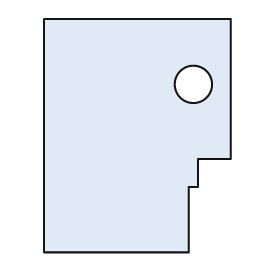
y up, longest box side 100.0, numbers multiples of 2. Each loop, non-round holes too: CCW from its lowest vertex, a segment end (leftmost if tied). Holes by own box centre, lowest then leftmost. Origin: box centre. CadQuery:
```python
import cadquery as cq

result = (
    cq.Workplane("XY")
    .moveTo(-40.0, -50.0)
    .lineTo(22.0, -50.0)
    .lineTo(22.0, -22.0)
    .lineTo(26.0, -22.0)
    .lineTo(26.0, -10.0)
    .lineTo(40.0, -10.0)
    .lineTo(40.0, 50.0)
    .lineTo(-40.0, 50.0)
    .close()
    .moveTo(24.0, 22.0)
    .circle(8.0)
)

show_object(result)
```